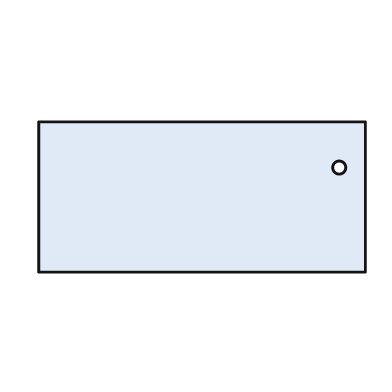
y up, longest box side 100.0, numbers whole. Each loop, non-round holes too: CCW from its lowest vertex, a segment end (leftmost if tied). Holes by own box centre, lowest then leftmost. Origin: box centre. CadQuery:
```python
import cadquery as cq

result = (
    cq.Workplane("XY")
    .moveTo(-50.0, -23.0)
    .lineTo(50.0, -23.0)
    .lineTo(50.0, 23.0)
    .lineTo(-50.0, 23.0)
    .close()
    .moveTo(42.0, 9.0)
    .circle(2.0)
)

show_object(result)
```